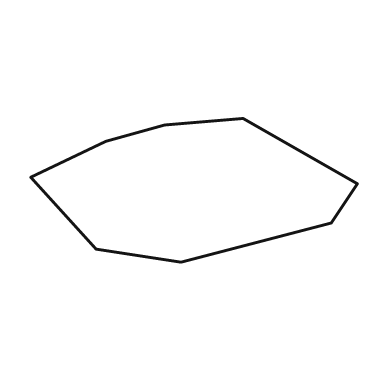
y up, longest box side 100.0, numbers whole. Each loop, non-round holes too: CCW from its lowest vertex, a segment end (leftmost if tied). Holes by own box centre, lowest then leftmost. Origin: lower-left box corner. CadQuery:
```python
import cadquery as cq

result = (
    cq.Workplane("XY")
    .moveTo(46.0, 0.0)
    .lineTo(92.0, 12.0)
    .lineTo(100.0, 24.0)
    .lineTo(65.0, 44.0)
    .lineTo(41.0, 42.0)
    .lineTo(23.0, 37.0)
    .lineTo(0.0, 26.0)
    .lineTo(20.0, 4.0)
    .close()
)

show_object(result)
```